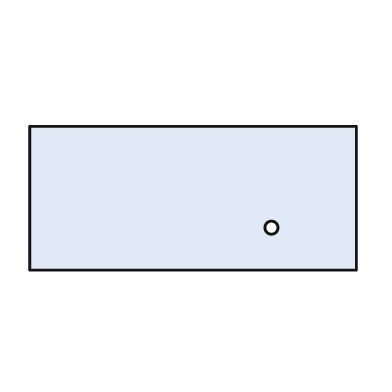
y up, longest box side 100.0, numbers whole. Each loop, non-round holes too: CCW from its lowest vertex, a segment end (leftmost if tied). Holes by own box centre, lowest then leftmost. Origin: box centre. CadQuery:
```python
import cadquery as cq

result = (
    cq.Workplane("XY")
    .moveTo(-50.0, -22.0)
    .lineTo(50.0, -22.0)
    .lineTo(50.0, 22.0)
    .lineTo(-50.0, 22.0)
    .close()
    .moveTo(24.0, -9.0)
    .circle(2.0)
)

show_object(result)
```